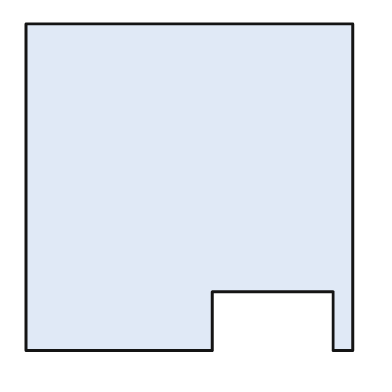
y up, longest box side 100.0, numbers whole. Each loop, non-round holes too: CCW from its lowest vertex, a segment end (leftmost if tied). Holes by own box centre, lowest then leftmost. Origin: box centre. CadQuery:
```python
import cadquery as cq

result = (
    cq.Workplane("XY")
    .moveTo(-50.0, -50.0)
    .lineTo(7.0, -50.0)
    .lineTo(7.0, -32.0)
    .lineTo(44.0, -32.0)
    .lineTo(44.0, -50.0)
    .lineTo(50.0, -50.0)
    .lineTo(50.0, 50.0)
    .lineTo(-50.0, 50.0)
    .close()
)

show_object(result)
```